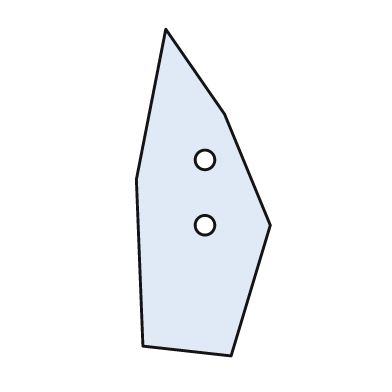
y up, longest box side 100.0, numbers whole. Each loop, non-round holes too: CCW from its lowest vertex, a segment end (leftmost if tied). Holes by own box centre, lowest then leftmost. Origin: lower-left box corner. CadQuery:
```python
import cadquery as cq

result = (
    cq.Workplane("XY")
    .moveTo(29.0, 0.0)
    .lineTo(41.0, 40.0)
    .lineTo(27.0, 74.0)
    .lineTo(9.0, 100.0)
    .lineTo(0.0, 54.0)
    .lineTo(2.0, 3.0)
    .close()
    .moveTo(21.0, 40.0)
    .circle(3.0)
    .moveTo(21.0, 60.0)
    .circle(3.0)
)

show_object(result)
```